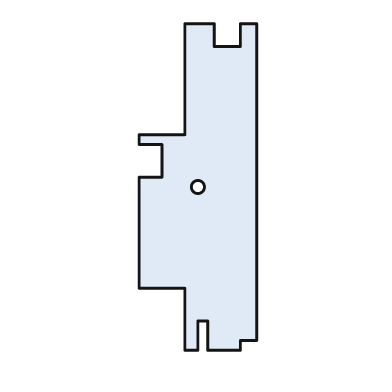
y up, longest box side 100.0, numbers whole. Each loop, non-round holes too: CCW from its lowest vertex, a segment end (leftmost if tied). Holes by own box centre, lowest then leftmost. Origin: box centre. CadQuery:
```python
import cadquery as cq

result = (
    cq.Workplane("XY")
    .moveTo(-4.0, -50.0)
    .lineTo(0.0, -50.0)
    .lineTo(0.0, -41.0)
    .lineTo(3.0, -41.0)
    .lineTo(3.0, -50.0)
    .lineTo(13.0, -50.0)
    .lineTo(13.0, -47.0)
    .lineTo(18.0, -47.0)
    .lineTo(18.0, 50.0)
    .lineTo(13.0, 50.0)
    .lineTo(13.0, 43.0)
    .lineTo(5.0, 43.0)
    .lineTo(5.0, 50.0)
    .lineTo(-4.0, 50.0)
    .lineTo(-4.0, 16.0)
    .lineTo(-18.0, 16.0)
    .lineTo(-18.0, 13.0)
    .lineTo(-11.0, 13.0)
    .lineTo(-11.0, 3.0)
    .lineTo(-18.0, 3.0)
    .lineTo(-18.0, -31.0)
    .lineTo(-4.0, -31.0)
    .close()
    .moveTo(0.0, 0.0)
    .circle(2.0)
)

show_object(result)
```